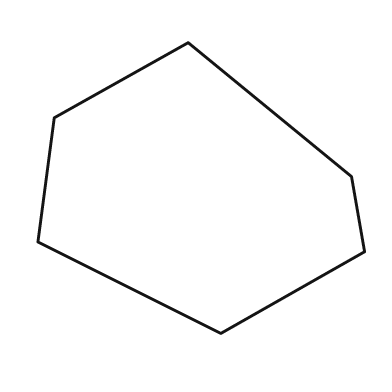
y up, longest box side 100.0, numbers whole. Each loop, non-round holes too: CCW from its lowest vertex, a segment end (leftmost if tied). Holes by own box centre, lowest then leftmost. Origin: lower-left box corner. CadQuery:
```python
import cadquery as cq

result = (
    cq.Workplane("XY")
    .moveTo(56.0, 0.0)
    .lineTo(100.0, 25.0)
    .lineTo(96.0, 48.0)
    .lineTo(46.0, 89.0)
    .lineTo(5.0, 66.0)
    .lineTo(0.0, 28.0)
    .close()
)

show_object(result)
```